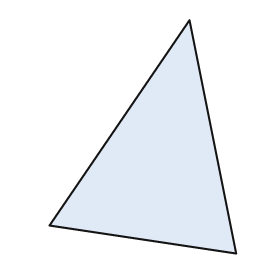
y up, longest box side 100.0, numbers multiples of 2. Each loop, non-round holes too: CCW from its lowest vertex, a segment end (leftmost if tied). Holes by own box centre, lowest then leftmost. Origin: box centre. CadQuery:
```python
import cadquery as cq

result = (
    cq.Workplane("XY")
    .moveTo(40.0, -50.0)
    .lineTo(20.0, 50.0)
    .lineTo(-40.0, -38.0)
    .close()
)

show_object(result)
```